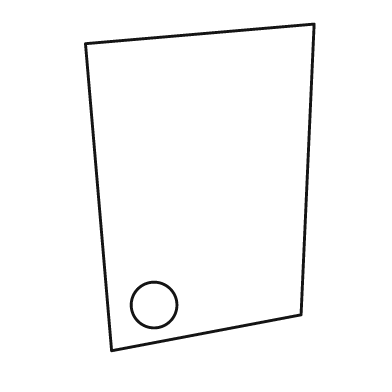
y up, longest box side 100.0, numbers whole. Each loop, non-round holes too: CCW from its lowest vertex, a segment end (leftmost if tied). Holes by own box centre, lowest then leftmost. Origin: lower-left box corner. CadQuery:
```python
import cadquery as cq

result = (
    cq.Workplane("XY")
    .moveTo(8.0, 0.0)
    .lineTo(66.0, 11.0)
    .lineTo(70.0, 100.0)
    .lineTo(0.0, 94.0)
    .close()
    .moveTo(21.0, 14.0)
    .circle(7.0)
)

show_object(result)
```